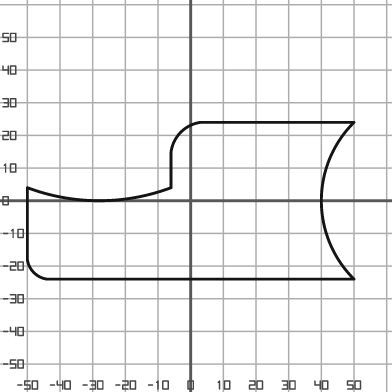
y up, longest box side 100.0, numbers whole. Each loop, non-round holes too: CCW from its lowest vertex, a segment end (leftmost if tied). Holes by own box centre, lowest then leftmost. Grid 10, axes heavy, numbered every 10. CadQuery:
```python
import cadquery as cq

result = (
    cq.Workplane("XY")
    .moveTo(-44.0, -24.0)
    .lineTo(50.0, -24.0)
    .threePointArc((40.0, 0.0), (50.0, 24.0))
    .lineTo(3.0, 24.0)
    .threePointArc((-3.0, 21.0), (-6.0, 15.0))
    .lineTo(-6.0, 4.0)
    .threePointArc((-28.0, 0.0), (-50.0, 4.0))
    .lineTo(-50.0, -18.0)
    .threePointArc((-48.0, -22.0), (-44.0, -24.0))
    .close()
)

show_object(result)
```